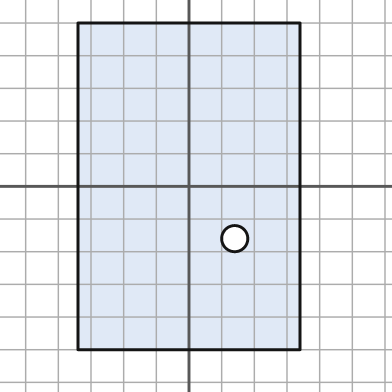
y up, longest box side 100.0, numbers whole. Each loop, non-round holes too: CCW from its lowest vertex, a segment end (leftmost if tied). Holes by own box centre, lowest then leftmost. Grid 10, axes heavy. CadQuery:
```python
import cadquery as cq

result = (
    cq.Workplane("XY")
    .moveTo(-34.0, -50.0)
    .lineTo(34.0, -50.0)
    .lineTo(34.0, 50.0)
    .lineTo(-34.0, 50.0)
    .close()
    .moveTo(14.0, -16.0)
    .circle(4.0)
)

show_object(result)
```